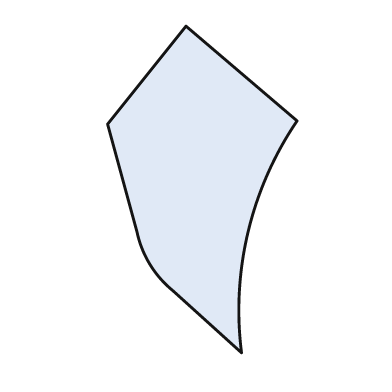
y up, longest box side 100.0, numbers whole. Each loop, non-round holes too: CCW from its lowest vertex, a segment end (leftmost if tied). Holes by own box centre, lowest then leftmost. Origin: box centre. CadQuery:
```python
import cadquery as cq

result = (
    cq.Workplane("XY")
    .moveTo(12.0, -50.0)
    .threePointArc((14.0, -13.0), (29.0, 21.0))
    .lineTo(-5.0, 50.0)
    .lineTo(-29.0, 20.0)
    .lineTo(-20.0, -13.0)
    .threePointArc((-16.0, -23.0), (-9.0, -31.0))
    .close()
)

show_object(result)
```